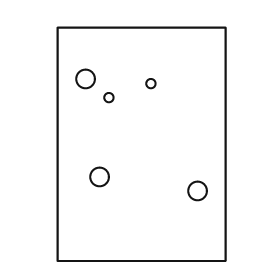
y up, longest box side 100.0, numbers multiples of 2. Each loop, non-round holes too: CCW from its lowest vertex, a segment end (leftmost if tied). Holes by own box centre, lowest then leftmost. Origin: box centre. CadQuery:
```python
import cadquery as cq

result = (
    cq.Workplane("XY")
    .moveTo(-36.0, -50.0)
    .lineTo(36.0, -50.0)
    .lineTo(36.0, 50.0)
    .lineTo(-36.0, 50.0)
    .close()
    .moveTo(24.0, -20.0)
    .circle(4.0)
    .moveTo(-18.0, -14.0)
    .circle(4.0)
    .moveTo(-14.0, 20.0)
    .circle(2.0)
    .moveTo(4.0, 26.0)
    .circle(2.0)
    .moveTo(-24.0, 28.0)
    .circle(4.0)
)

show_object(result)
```